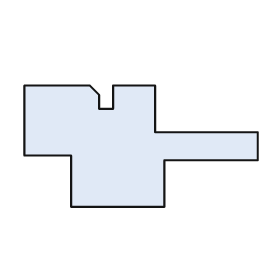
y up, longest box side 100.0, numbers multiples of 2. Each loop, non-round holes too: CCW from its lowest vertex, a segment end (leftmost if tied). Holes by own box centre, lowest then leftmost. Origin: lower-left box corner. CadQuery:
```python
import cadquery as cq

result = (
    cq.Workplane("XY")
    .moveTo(20.0, 0.0)
    .lineTo(60.0, 0.0)
    .lineTo(60.0, 20.0)
    .lineTo(100.0, 20.0)
    .lineTo(100.0, 32.0)
    .lineTo(56.0, 32.0)
    .lineTo(56.0, 52.0)
    .lineTo(38.0, 52.0)
    .lineTo(38.0, 42.0)
    .lineTo(32.0, 42.0)
    .lineTo(32.0, 48.0)
    .lineTo(28.0, 52.0)
    .lineTo(0.0, 52.0)
    .lineTo(0.0, 22.0)
    .lineTo(20.0, 22.0)
    .close()
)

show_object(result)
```